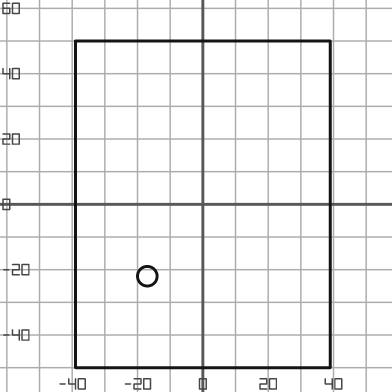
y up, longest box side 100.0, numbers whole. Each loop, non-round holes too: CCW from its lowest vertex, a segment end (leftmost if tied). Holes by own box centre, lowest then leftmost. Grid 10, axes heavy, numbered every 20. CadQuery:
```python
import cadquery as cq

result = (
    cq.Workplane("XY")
    .moveTo(-39.0, -50.0)
    .lineTo(39.0, -50.0)
    .lineTo(39.0, 50.0)
    .lineTo(-39.0, 50.0)
    .close()
    .moveTo(-17.0, -22.0)
    .circle(3.0)
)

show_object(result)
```